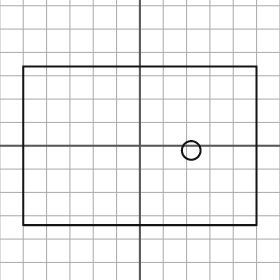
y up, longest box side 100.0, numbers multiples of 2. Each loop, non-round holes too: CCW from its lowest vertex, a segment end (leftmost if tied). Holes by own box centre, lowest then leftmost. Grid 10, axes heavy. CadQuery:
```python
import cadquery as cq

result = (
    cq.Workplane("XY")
    .moveTo(-50.0, -34.0)
    .lineTo(50.0, -34.0)
    .lineTo(50.0, 34.0)
    .lineTo(-50.0, 34.0)
    .close()
    .moveTo(22.0, -2.0)
    .circle(4.0)
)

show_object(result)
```